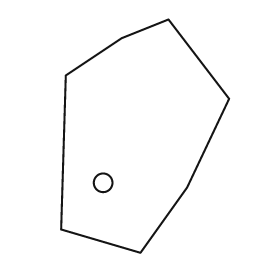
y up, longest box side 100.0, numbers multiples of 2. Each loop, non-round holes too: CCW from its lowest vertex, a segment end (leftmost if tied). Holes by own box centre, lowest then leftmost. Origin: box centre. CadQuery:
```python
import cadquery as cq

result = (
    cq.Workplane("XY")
    .moveTo(-2.0, -50.0)
    .lineTo(18.0, -22.0)
    .lineTo(36.0, 16.0)
    .lineTo(10.0, 50.0)
    .lineTo(-10.0, 42.0)
    .lineTo(-34.0, 26.0)
    .lineTo(-36.0, -40.0)
    .close()
    .moveTo(-18.0, -20.0)
    .circle(4.0)
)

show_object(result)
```